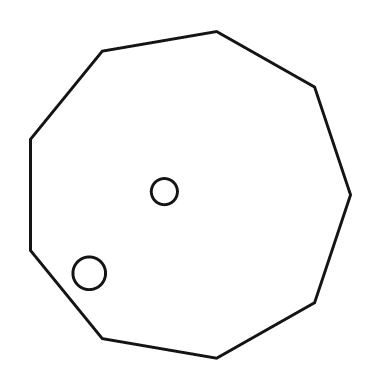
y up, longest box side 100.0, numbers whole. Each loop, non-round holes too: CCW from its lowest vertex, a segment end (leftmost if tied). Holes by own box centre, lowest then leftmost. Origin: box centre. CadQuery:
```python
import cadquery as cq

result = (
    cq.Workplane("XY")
    .moveTo(8.0, -50.0)
    .lineTo(38.0, -33.0)
    .lineTo(49.0, 0.0)
    .lineTo(38.0, 33.0)
    .lineTo(8.0, 50.0)
    .lineTo(-27.0, 44.0)
    .lineTo(-49.0, 17.0)
    .lineTo(-49.0, -17.0)
    .lineTo(-27.0, -44.0)
    .close()
    .moveTo(-31.0, -24.0)
    .circle(5.0)
    .moveTo(-8.0, 1.0)
    .circle(4.0)
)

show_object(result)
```